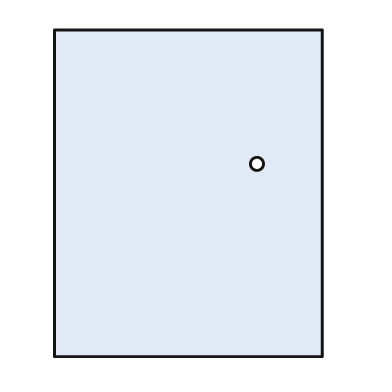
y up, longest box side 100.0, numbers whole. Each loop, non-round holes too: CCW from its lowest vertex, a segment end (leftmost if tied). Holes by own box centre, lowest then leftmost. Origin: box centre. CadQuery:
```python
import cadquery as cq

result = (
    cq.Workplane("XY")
    .moveTo(-41.0, -50.0)
    .lineTo(41.0, -50.0)
    .lineTo(41.0, 50.0)
    .lineTo(-41.0, 50.0)
    .close()
    .moveTo(21.0, 9.0)
    .circle(2.0)
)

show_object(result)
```